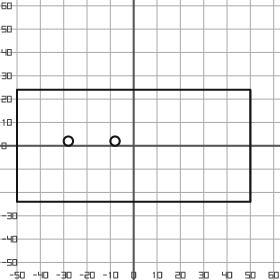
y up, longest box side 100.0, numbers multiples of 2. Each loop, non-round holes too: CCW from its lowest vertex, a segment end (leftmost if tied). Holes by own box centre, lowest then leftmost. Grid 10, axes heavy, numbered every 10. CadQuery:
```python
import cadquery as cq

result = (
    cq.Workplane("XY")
    .moveTo(-50.0, -24.0)
    .lineTo(50.0, -24.0)
    .lineTo(50.0, 24.0)
    .lineTo(-50.0, 24.0)
    .close()
    .moveTo(-28.0, 2.0)
    .circle(2.0)
    .moveTo(-8.0, 2.0)
    .circle(2.0)
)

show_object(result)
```